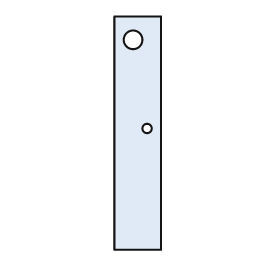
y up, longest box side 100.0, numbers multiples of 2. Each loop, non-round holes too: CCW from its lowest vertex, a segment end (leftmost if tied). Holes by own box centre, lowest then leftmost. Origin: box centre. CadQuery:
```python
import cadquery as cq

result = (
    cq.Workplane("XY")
    .moveTo(-10.0, -50.0)
    .lineTo(10.0, -50.0)
    .lineTo(10.0, 50.0)
    .lineTo(-10.0, 50.0)
    .close()
    .moveTo(4.0, 2.0)
    .circle(2.0)
    .moveTo(-2.0, 40.0)
    .circle(4.0)
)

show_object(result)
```